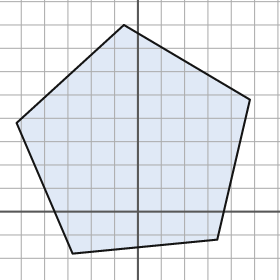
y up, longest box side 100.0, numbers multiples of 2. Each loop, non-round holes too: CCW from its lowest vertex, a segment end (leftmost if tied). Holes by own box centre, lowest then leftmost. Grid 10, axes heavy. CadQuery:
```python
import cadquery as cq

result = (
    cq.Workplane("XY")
    .moveTo(-28.0, -18.0)
    .lineTo(34.0, -12.0)
    .lineTo(48.0, 48.0)
    .lineTo(-6.0, 80.0)
    .lineTo(-52.0, 38.0)
    .close()
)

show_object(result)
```